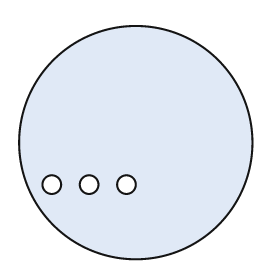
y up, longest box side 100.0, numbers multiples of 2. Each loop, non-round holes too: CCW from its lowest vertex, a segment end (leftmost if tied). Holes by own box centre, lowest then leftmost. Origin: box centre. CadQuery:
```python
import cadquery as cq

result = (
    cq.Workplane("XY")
    .moveTo(0.0, 0.0)
    .circle(50.0)
    .moveTo(-36.0, -18.0)
    .circle(4.0)
    .moveTo(-20.0, -18.0)
    .circle(4.0)
    .moveTo(-4.0, -18.0)
    .circle(4.0)
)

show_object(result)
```